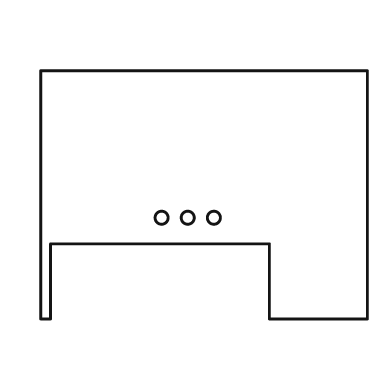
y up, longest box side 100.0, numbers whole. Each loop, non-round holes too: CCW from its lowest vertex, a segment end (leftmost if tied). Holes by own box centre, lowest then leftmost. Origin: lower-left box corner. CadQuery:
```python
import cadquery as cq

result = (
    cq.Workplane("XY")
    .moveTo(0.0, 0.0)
    .lineTo(3.0, 0.0)
    .lineTo(3.0, 23.0)
    .lineTo(70.0, 23.0)
    .lineTo(70.0, 0.0)
    .lineTo(100.0, 0.0)
    .lineTo(100.0, 76.0)
    .lineTo(0.0, 76.0)
    .close()
    .moveTo(37.0, 31.0)
    .circle(2.0)
    .moveTo(45.0, 31.0)
    .circle(2.0)
    .moveTo(53.0, 31.0)
    .circle(2.0)
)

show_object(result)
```